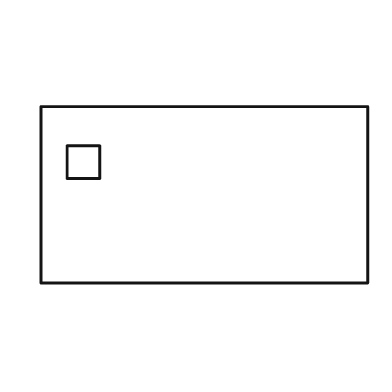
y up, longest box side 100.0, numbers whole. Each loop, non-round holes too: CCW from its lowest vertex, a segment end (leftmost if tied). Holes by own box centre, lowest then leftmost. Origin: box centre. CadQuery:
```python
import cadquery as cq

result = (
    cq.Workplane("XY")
    .moveTo(-50.0, -27.0)
    .lineTo(50.0, -27.0)
    .lineTo(50.0, 27.0)
    .lineTo(-50.0, 27.0)
    .close()
    .moveTo(-42.0, 5.0)
    .lineTo(-32.0, 5.0)
    .lineTo(-32.0, 15.0)
    .lineTo(-42.0, 15.0)
    .close()
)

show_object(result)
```